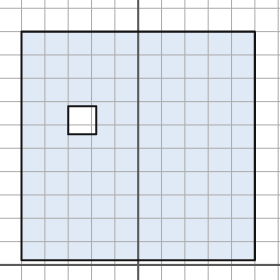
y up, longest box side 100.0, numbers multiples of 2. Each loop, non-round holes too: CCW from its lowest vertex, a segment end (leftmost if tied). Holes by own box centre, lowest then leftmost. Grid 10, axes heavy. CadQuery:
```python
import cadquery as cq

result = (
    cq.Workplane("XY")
    .moveTo(-50.0, 2.0)
    .lineTo(50.0, 2.0)
    .lineTo(50.0, 100.0)
    .lineTo(-50.0, 100.0)
    .close()
    .moveTo(-30.0, 56.0)
    .lineTo(-18.0, 56.0)
    .lineTo(-18.0, 68.0)
    .lineTo(-30.0, 68.0)
    .close()
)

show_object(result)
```